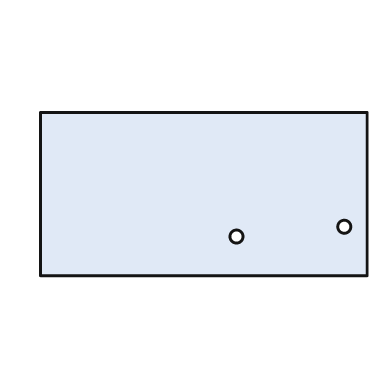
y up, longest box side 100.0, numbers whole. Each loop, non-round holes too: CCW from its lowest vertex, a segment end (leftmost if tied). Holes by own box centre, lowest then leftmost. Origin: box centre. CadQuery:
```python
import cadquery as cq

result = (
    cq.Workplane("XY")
    .moveTo(-50.0, -25.0)
    .lineTo(50.0, -25.0)
    .lineTo(50.0, 25.0)
    .lineTo(-50.0, 25.0)
    .close()
    .moveTo(10.0, -13.0)
    .circle(2.0)
    .moveTo(43.0, -10.0)
    .circle(2.0)
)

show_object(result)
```